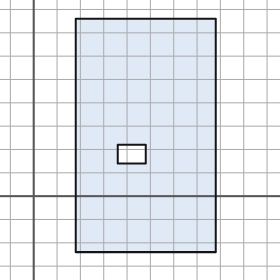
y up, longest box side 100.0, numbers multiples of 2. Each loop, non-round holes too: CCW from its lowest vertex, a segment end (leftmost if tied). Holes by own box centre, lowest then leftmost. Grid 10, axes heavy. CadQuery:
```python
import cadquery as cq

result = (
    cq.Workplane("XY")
    .moveTo(18.0, -24.0)
    .lineTo(78.0, -24.0)
    .lineTo(78.0, 76.0)
    .lineTo(18.0, 76.0)
    .close()
    .moveTo(36.0, 14.0)
    .lineTo(48.0, 14.0)
    .lineTo(48.0, 22.0)
    .lineTo(36.0, 22.0)
    .close()
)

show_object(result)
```